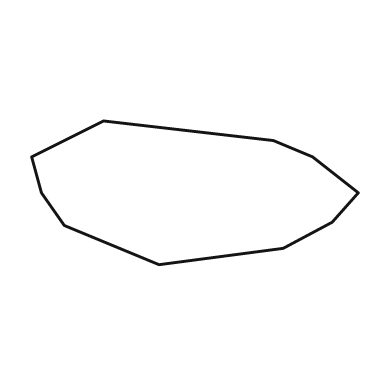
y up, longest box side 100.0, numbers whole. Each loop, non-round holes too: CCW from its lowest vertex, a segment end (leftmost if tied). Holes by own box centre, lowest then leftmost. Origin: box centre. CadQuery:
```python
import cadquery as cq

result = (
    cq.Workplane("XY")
    .moveTo(-11.0, -22.0)
    .lineTo(27.0, -17.0)
    .lineTo(42.0, -9.0)
    .lineTo(50.0, 0.0)
    .lineTo(36.0, 11.0)
    .lineTo(24.0, 16.0)
    .lineTo(-28.0, 22.0)
    .lineTo(-50.0, 11.0)
    .lineTo(-47.0, 0.0)
    .lineTo(-40.0, -10.0)
    .close()
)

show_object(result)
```